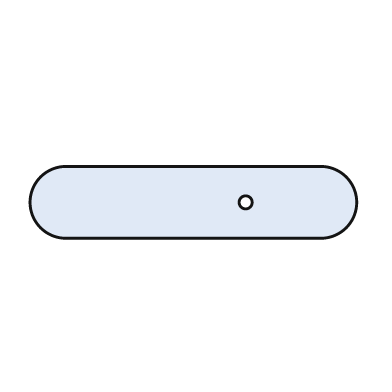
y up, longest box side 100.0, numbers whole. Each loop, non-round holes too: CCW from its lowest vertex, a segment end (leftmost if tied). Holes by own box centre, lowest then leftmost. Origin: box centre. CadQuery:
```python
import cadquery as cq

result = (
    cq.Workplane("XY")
    .moveTo(-39.0, -11.0)
    .lineTo(39.0, -11.0)
    .threePointArc((50.0, 0.0), (39.0, 11.0))
    .lineTo(-39.0, 11.0)
    .threePointArc((-50.0, 0.0), (-39.0, -11.0))
    .close()
    .moveTo(16.0, 0.0)
    .circle(2.0)
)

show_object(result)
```